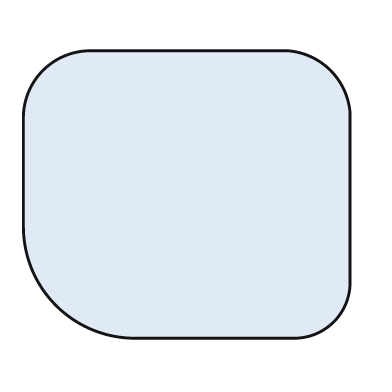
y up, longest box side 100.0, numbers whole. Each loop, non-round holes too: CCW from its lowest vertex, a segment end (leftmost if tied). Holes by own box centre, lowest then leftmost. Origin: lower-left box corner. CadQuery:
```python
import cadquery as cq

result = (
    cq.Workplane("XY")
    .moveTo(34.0, 0.0)
    .lineTo(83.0, 0.0)
    .threePointArc((95.0, 5.0), (100.0, 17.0))
    .lineTo(100.0, 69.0)
    .threePointArc((94.0, 82.0), (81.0, 88.0))
    .lineTo(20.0, 88.0)
    .threePointArc((6.0, 82.0), (0.0, 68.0))
    .lineTo(0.0, 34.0)
    .threePointArc((10.0, 10.0), (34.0, 0.0))
    .close()
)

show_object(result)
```